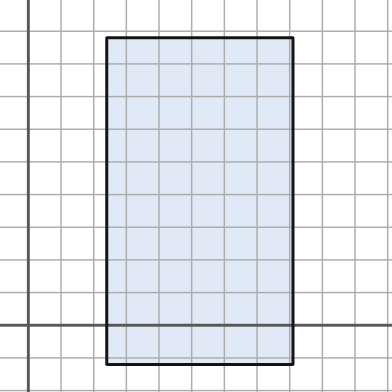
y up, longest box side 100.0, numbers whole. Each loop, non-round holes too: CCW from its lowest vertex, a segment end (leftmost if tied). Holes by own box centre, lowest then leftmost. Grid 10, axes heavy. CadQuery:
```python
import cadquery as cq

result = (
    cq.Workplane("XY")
    .moveTo(24.0, -12.0)
    .lineTo(81.0, -12.0)
    .lineTo(81.0, 88.0)
    .lineTo(24.0, 88.0)
    .close()
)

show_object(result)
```